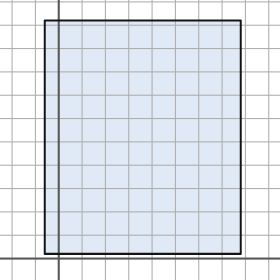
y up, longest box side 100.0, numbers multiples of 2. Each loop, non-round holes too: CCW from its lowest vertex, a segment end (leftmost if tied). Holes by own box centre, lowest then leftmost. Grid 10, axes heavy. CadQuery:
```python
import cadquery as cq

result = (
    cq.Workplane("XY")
    .moveTo(-6.0, 2.0)
    .lineTo(78.0, 2.0)
    .lineTo(78.0, 102.0)
    .lineTo(-6.0, 102.0)
    .close()
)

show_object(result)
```